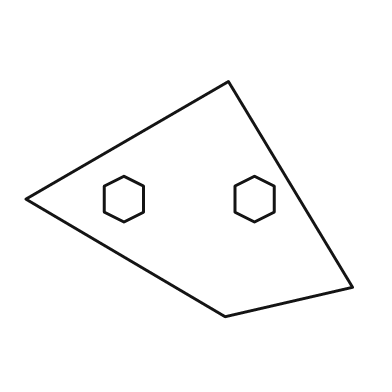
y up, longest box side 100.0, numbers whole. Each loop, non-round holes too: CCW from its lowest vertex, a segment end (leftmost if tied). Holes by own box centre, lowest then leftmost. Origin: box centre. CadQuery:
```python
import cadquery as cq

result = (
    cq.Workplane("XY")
    .moveTo(11.0, -36.0)
    .lineTo(50.0, -27.0)
    .lineTo(12.0, 36.0)
    .lineTo(-50.0, 0.0)
    .close()
    .moveTo(-20.0, -7.0)
    .lineTo(-14.0, -4.0)
    .lineTo(-14.0, 4.0)
    .lineTo(-20.0, 7.0)
    .lineTo(-26.0, 4.0)
    .lineTo(-26.0, -4.0)
    .close()
    .moveTo(20.0, -7.0)
    .lineTo(26.0, -4.0)
    .lineTo(26.0, 4.0)
    .lineTo(20.0, 7.0)
    .lineTo(14.0, 4.0)
    .lineTo(14.0, -4.0)
    .close()
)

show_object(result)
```